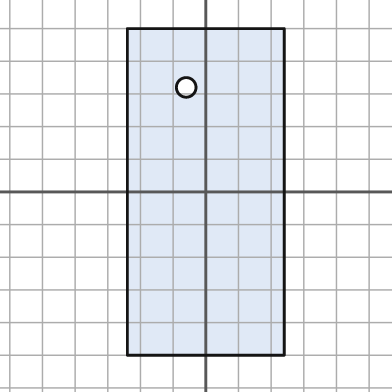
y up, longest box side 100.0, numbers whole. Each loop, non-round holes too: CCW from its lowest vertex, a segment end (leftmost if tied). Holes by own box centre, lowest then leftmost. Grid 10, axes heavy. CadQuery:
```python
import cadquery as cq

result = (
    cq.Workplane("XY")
    .moveTo(-24.0, -50.0)
    .lineTo(24.0, -50.0)
    .lineTo(24.0, 50.0)
    .lineTo(-24.0, 50.0)
    .close()
    .moveTo(-6.0, 32.0)
    .circle(3.0)
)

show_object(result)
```